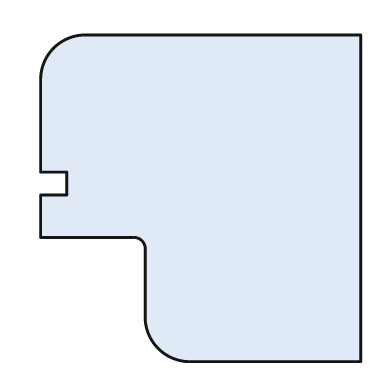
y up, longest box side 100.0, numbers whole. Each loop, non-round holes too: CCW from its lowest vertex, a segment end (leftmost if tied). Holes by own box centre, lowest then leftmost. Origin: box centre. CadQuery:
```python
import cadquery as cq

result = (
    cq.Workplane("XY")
    .moveTo(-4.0, -50.0)
    .lineTo(49.0, -50.0)
    .lineTo(49.0, 50.0)
    .lineTo(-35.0, 50.0)
    .threePointArc((-45.0, 46.0), (-49.0, 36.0))
    .lineTo(-49.0, 8.0)
    .lineTo(-41.0, 8.0)
    .lineTo(-41.0, 1.0)
    .lineTo(-49.0, 1.0)
    .lineTo(-49.0, -12.0)
    .lineTo(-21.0, -12.0)
    .threePointArc((-18.0, -13.0), (-17.0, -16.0))
    .lineTo(-17.0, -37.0)
    .threePointArc((-13.0, -46.0), (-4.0, -50.0))
    .close()
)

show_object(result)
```